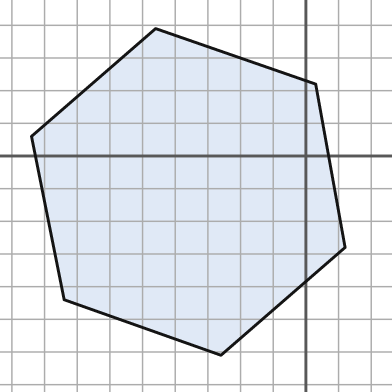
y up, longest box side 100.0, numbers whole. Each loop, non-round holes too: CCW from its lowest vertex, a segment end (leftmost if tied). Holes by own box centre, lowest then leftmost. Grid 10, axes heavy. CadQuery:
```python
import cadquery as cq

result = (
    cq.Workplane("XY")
    .moveTo(-26.0, -61.0)
    .lineTo(12.0, -28.0)
    .lineTo(3.0, 22.0)
    .lineTo(-46.0, 39.0)
    .lineTo(-84.0, 6.0)
    .lineTo(-74.0, -44.0)
    .close()
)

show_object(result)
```